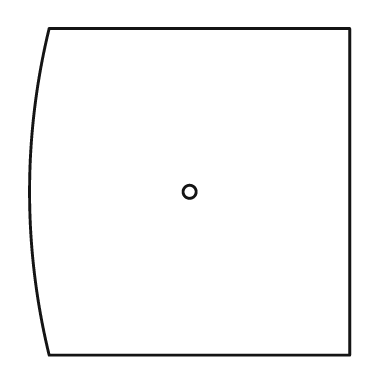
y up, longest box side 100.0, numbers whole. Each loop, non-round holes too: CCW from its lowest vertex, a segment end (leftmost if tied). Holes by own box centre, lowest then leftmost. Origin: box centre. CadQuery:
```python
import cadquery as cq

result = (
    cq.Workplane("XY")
    .moveTo(-43.0, -50.0)
    .lineTo(49.0, -50.0)
    .lineTo(49.0, 50.0)
    .lineTo(-43.0, 50.0)
    .threePointArc((-49.0, 0.0), (-43.0, -50.0))
    .close()
    .moveTo(0.0, 0.0)
    .circle(2.0)
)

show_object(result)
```